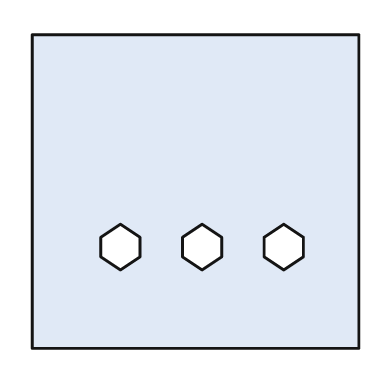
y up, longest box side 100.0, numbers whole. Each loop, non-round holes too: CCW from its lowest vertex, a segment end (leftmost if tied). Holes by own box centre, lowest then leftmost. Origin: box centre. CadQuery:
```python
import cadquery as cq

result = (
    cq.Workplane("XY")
    .moveTo(-50.0, -48.0)
    .lineTo(50.0, -48.0)
    .lineTo(50.0, 48.0)
    .lineTo(-50.0, 48.0)
    .close()
    .moveTo(-23.0, -24.0)
    .lineTo(-17.0, -20.0)
    .lineTo(-17.0, -14.0)
    .lineTo(-23.0, -10.0)
    .lineTo(-29.0, -14.0)
    .lineTo(-29.0, -20.0)
    .close()
    .moveTo(2.0, -24.0)
    .lineTo(8.0, -20.0)
    .lineTo(8.0, -14.0)
    .lineTo(2.0, -10.0)
    .lineTo(-4.0, -14.0)
    .lineTo(-4.0, -20.0)
    .close()
    .moveTo(27.0, -24.0)
    .lineTo(33.0, -20.0)
    .lineTo(33.0, -14.0)
    .lineTo(27.0, -10.0)
    .lineTo(21.0, -14.0)
    .lineTo(21.0, -20.0)
    .close()
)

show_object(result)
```